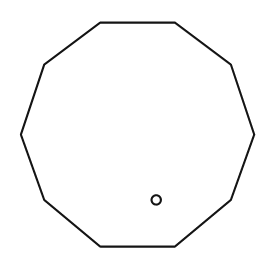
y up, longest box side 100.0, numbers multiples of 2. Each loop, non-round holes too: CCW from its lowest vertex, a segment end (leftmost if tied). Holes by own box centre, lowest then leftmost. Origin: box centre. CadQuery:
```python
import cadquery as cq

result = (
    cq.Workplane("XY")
    .moveTo(-16.0, -48.0)
    .lineTo(16.0, -48.0)
    .lineTo(40.0, -28.0)
    .lineTo(50.0, 0.0)
    .lineTo(40.0, 30.0)
    .lineTo(16.0, 48.0)
    .lineTo(-16.0, 48.0)
    .lineTo(-40.0, 30.0)
    .lineTo(-50.0, 0.0)
    .lineTo(-40.0, -28.0)
    .close()
    .moveTo(8.0, -28.0)
    .circle(2.0)
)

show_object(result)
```